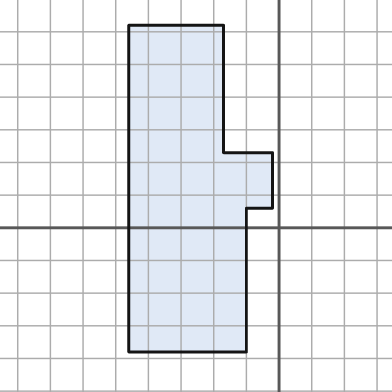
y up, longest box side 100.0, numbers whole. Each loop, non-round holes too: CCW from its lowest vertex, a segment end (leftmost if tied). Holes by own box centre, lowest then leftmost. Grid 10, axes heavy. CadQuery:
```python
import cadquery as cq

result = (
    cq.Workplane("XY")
    .moveTo(-46.0, -38.0)
    .lineTo(-10.0, -38.0)
    .lineTo(-10.0, 6.0)
    .lineTo(-2.0, 6.0)
    .lineTo(-2.0, 23.0)
    .lineTo(-17.0, 23.0)
    .lineTo(-17.0, 62.0)
    .lineTo(-46.0, 62.0)
    .close()
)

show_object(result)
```